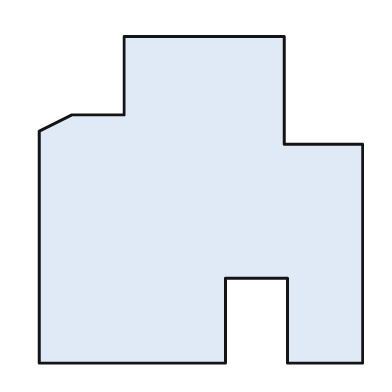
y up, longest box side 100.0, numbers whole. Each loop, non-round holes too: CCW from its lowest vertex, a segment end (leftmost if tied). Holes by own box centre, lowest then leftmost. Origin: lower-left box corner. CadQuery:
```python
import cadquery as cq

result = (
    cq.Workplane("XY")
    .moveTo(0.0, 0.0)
    .lineTo(57.0, 0.0)
    .lineTo(57.0, 26.0)
    .lineTo(76.0, 26.0)
    .lineTo(76.0, 0.0)
    .lineTo(99.0, 0.0)
    .lineTo(99.0, 67.0)
    .lineTo(75.0, 67.0)
    .lineTo(75.0, 100.0)
    .lineTo(26.0, 100.0)
    .lineTo(26.0, 76.0)
    .lineTo(10.0, 76.0)
    .lineTo(0.0, 71.0)
    .close()
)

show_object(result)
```